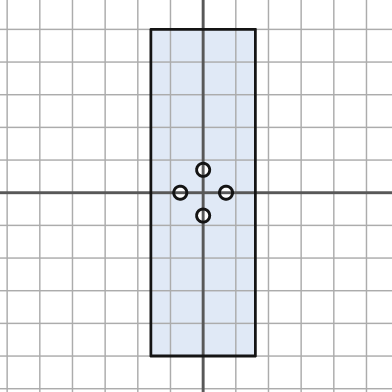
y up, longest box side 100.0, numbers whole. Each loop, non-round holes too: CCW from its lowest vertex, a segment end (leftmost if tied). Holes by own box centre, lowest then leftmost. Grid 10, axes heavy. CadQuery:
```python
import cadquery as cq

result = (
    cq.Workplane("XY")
    .moveTo(-16.0, -50.0)
    .lineTo(16.0, -50.0)
    .lineTo(16.0, 50.0)
    .lineTo(-16.0, 50.0)
    .close()
    .moveTo(0.0, -7.0)
    .circle(2.0)
    .moveTo(-7.0, 0.0)
    .circle(2.0)
    .moveTo(7.0, 0.0)
    .circle(2.0)
    .moveTo(0.0, 7.0)
    .circle(2.0)
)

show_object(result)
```